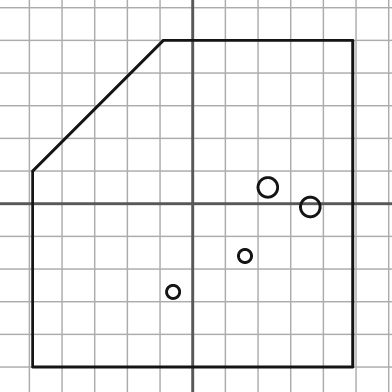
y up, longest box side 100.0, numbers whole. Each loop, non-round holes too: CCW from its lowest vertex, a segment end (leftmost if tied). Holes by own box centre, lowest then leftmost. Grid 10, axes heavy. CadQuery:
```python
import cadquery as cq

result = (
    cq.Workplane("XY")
    .moveTo(-49.0, -50.0)
    .lineTo(49.0, -50.0)
    .lineTo(49.0, 50.0)
    .lineTo(-9.0, 50.0)
    .lineTo(-49.0, 10.0)
    .close()
    .moveTo(-6.0, -27.0)
    .circle(2.0)
    .moveTo(16.0, -16.0)
    .circle(2.0)
    .moveTo(36.0, -1.0)
    .circle(3.0)
    .moveTo(23.0, 5.0)
    .circle(3.0)
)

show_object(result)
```